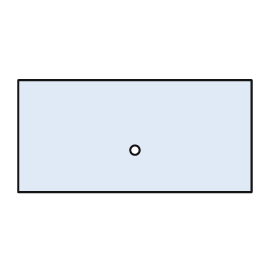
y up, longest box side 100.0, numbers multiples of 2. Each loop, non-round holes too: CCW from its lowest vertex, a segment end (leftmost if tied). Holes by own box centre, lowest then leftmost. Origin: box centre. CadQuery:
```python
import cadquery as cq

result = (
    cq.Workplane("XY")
    .moveTo(-50.0, -24.0)
    .lineTo(50.0, -24.0)
    .lineTo(50.0, 24.0)
    .lineTo(-50.0, 24.0)
    .close()
    .moveTo(0.0, -6.0)
    .circle(2.0)
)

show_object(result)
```